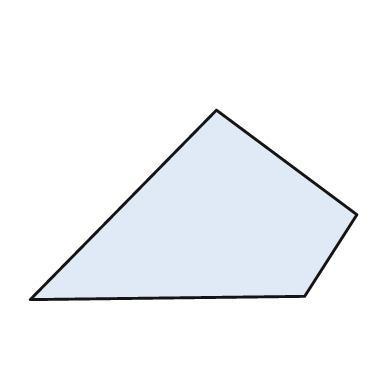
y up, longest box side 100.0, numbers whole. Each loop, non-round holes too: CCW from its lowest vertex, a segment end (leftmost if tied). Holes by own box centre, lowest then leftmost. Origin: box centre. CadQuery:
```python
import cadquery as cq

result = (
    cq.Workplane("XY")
    .moveTo(-50.0, -29.0)
    .lineTo(34.0, -28.0)
    .lineTo(50.0, -3.0)
    .lineTo(7.0, 29.0)
    .close()
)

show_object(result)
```